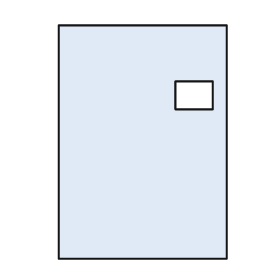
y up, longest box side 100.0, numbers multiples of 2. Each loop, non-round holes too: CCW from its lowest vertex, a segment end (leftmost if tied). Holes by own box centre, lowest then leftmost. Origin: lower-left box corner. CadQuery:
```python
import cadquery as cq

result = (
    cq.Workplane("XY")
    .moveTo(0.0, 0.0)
    .lineTo(72.0, 0.0)
    .lineTo(72.0, 100.0)
    .lineTo(0.0, 100.0)
    .close()
    .moveTo(50.0, 64.0)
    .lineTo(66.0, 64.0)
    .lineTo(66.0, 76.0)
    .lineTo(50.0, 76.0)
    .close()
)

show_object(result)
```